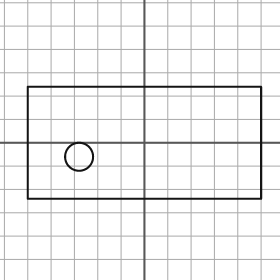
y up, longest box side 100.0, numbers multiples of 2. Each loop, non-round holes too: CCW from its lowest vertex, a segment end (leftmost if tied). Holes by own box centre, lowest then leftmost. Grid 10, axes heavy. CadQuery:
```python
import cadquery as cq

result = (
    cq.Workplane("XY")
    .moveTo(-50.0, -24.0)
    .lineTo(50.0, -24.0)
    .lineTo(50.0, 24.0)
    .lineTo(-50.0, 24.0)
    .close()
    .moveTo(-28.0, -6.0)
    .circle(6.0)
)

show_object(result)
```